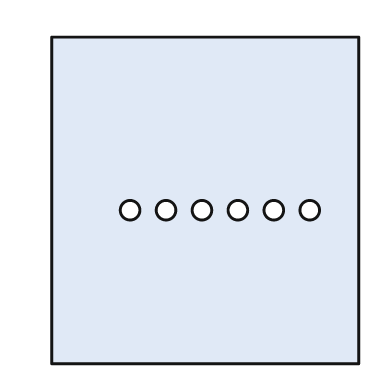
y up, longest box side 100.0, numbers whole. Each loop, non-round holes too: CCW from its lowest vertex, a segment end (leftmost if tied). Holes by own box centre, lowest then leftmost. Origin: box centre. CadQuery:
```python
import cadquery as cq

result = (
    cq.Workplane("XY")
    .moveTo(-47.0, -50.0)
    .lineTo(47.0, -50.0)
    .lineTo(47.0, 50.0)
    .lineTo(-47.0, 50.0)
    .close()
    .moveTo(-23.0, -3.0)
    .circle(3.0)
    .moveTo(-12.0, -3.0)
    .circle(3.0)
    .moveTo(-1.0, -3.0)
    .circle(3.0)
    .moveTo(10.0, -3.0)
    .circle(3.0)
    .moveTo(21.0, -3.0)
    .circle(3.0)
    .moveTo(32.0, -3.0)
    .circle(3.0)
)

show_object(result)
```